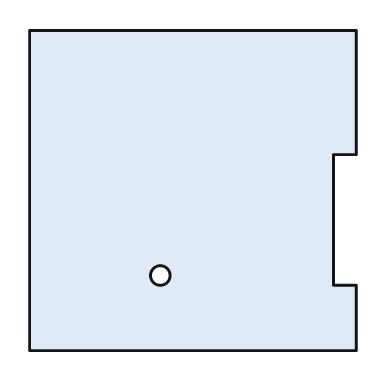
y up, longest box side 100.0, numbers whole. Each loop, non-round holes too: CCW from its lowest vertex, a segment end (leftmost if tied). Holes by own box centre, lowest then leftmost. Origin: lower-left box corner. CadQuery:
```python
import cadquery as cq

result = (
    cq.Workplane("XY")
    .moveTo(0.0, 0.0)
    .lineTo(100.0, 0.0)
    .lineTo(100.0, 20.0)
    .lineTo(93.0, 20.0)
    .lineTo(93.0, 60.0)
    .lineTo(100.0, 60.0)
    .lineTo(100.0, 98.0)
    .lineTo(0.0, 98.0)
    .close()
    .moveTo(40.0, 23.0)
    .circle(3.0)
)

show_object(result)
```